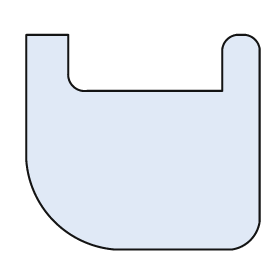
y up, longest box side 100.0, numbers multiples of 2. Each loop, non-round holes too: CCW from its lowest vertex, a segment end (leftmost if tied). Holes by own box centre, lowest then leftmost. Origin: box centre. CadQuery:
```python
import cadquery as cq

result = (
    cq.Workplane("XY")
    .moveTo(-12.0, -46.0)
    .lineTo(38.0, -46.0)
    .threePointArc((46.0, -42.0), (50.0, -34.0))
    .lineTo(50.0, 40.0)
    .threePointArc((48.0, 44.0), (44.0, 46.0))
    .lineTo(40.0, 46.0)
    .threePointArc((36.0, 44.0), (34.0, 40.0))
    .lineTo(34.0, 22.0)
    .lineTo(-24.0, 22.0)
    .threePointArc((-30.0, 24.0), (-32.0, 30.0))
    .lineTo(-32.0, 46.0)
    .lineTo(-50.0, 46.0)
    .lineTo(-50.0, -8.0)
    .threePointArc((-38.0, -34.0), (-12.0, -46.0))
    .close()
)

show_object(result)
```